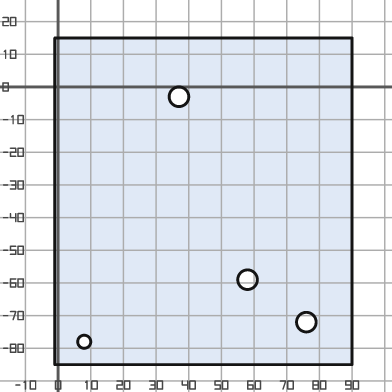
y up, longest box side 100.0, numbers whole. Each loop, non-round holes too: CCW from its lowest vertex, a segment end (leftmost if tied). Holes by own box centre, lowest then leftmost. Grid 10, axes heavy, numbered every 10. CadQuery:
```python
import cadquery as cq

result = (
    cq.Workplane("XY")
    .moveTo(-1.0, -85.0)
    .lineTo(90.0, -85.0)
    .lineTo(90.0, 15.0)
    .lineTo(-1.0, 15.0)
    .close()
    .moveTo(8.0, -78.0)
    .circle(2.0)
    .moveTo(76.0, -72.0)
    .circle(3.0)
    .moveTo(58.0, -59.0)
    .circle(3.0)
    .moveTo(37.0, -3.0)
    .circle(3.0)
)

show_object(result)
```